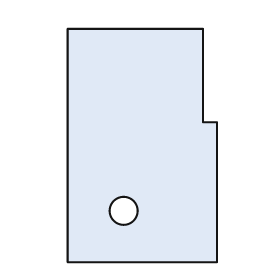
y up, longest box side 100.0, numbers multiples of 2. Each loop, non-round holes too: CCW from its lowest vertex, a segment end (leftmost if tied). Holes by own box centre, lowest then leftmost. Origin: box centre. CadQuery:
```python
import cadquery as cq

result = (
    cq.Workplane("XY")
    .moveTo(-32.0, -50.0)
    .lineTo(32.0, -50.0)
    .lineTo(32.0, 10.0)
    .lineTo(26.0, 10.0)
    .lineTo(26.0, 50.0)
    .lineTo(-32.0, 50.0)
    .close()
    .moveTo(-8.0, -28.0)
    .circle(6.0)
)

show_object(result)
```